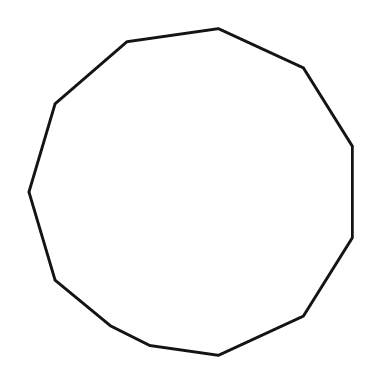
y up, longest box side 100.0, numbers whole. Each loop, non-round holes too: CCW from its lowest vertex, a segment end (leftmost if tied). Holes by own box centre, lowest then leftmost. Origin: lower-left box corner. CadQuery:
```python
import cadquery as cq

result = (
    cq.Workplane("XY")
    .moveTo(58.0, 0.0)
    .lineTo(84.0, 12.0)
    .lineTo(99.0, 36.0)
    .lineTo(99.0, 64.0)
    .lineTo(84.0, 88.0)
    .lineTo(58.0, 100.0)
    .lineTo(30.0, 96.0)
    .lineTo(8.0, 77.0)
    .lineTo(0.0, 50.0)
    .lineTo(8.0, 23.0)
    .lineTo(25.0, 9.0)
    .lineTo(37.0, 3.0)
    .close()
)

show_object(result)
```